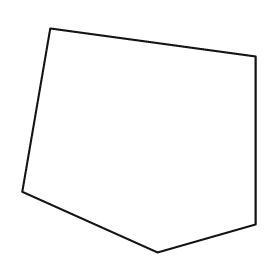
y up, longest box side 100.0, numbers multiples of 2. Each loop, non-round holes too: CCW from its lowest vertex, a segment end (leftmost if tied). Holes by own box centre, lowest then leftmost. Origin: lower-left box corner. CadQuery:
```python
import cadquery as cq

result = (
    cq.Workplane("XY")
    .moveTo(58.0, 0.0)
    .lineTo(100.0, 12.0)
    .lineTo(100.0, 84.0)
    .lineTo(12.0, 96.0)
    .lineTo(0.0, 26.0)
    .close()
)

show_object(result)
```